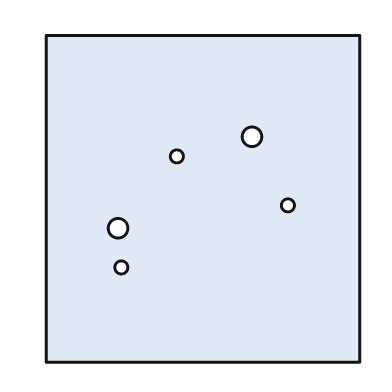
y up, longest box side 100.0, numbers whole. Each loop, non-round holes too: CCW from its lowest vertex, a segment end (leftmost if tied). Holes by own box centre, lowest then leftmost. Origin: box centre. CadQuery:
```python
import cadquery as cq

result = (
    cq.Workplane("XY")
    .moveTo(-48.0, -50.0)
    .lineTo(48.0, -50.0)
    .lineTo(48.0, 50.0)
    .lineTo(-48.0, 50.0)
    .close()
    .moveTo(-25.0, -21.0)
    .circle(2.0)
    .moveTo(-26.0, -9.0)
    .circle(3.0)
    .moveTo(26.0, -2.0)
    .circle(2.0)
    .moveTo(-8.0, 13.0)
    .circle(2.0)
    .moveTo(15.0, 19.0)
    .circle(3.0)
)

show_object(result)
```